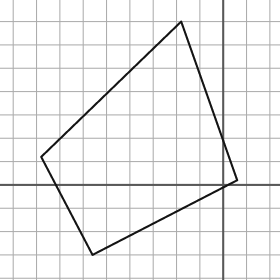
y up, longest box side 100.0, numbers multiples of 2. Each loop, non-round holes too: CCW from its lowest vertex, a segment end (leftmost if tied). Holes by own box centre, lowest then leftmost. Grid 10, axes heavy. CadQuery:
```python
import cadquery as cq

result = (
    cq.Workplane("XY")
    .moveTo(-56.0, -30.0)
    .lineTo(6.0, 2.0)
    .lineTo(-18.0, 70.0)
    .lineTo(-78.0, 12.0)
    .close()
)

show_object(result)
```